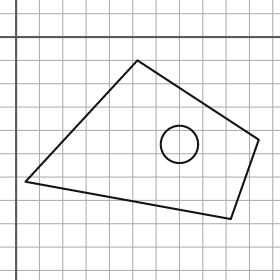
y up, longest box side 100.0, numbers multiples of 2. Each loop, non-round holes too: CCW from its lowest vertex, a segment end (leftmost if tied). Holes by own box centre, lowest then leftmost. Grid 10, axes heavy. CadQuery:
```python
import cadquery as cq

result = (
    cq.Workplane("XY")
    .moveTo(92.0, -78.0)
    .lineTo(104.0, -44.0)
    .lineTo(52.0, -10.0)
    .lineTo(4.0, -62.0)
    .close()
    .moveTo(70.0, -46.0)
    .circle(8.0)
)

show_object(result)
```